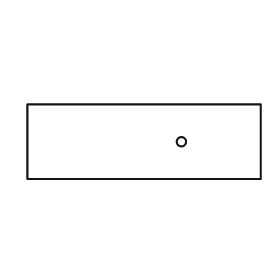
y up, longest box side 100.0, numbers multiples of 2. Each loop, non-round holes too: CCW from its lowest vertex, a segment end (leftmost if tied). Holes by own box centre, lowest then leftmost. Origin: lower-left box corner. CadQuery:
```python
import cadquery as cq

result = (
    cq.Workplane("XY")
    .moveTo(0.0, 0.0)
    .lineTo(100.0, 0.0)
    .lineTo(100.0, 32.0)
    .lineTo(0.0, 32.0)
    .close()
    .moveTo(66.0, 16.0)
    .circle(2.0)
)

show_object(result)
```